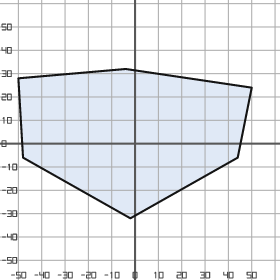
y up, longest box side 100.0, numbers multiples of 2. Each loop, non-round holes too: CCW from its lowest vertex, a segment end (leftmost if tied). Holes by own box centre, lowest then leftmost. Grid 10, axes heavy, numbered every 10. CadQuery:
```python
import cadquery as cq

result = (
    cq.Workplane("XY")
    .moveTo(-2.0, -32.0)
    .lineTo(44.0, -6.0)
    .lineTo(50.0, 24.0)
    .lineTo(-4.0, 32.0)
    .lineTo(-50.0, 28.0)
    .lineTo(-48.0, -6.0)
    .close()
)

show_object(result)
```